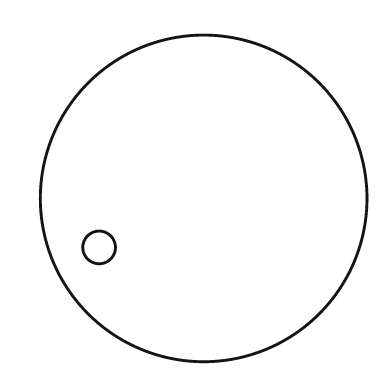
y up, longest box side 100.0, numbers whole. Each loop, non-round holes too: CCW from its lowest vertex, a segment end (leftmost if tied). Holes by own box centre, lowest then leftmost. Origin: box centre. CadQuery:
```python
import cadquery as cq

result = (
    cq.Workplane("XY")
    .moveTo(0.0, 0.0)
    .circle(50.0)
    .moveTo(-32.0, -15.0)
    .circle(5.0)
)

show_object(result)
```